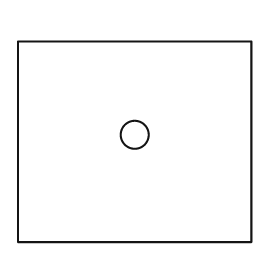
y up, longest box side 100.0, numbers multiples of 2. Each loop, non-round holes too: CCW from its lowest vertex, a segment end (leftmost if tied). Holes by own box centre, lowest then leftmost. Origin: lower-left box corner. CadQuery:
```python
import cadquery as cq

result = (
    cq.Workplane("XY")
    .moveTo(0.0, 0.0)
    .lineTo(100.0, 0.0)
    .lineTo(100.0, 86.0)
    .lineTo(0.0, 86.0)
    .close()
    .moveTo(50.0, 46.0)
    .circle(6.0)
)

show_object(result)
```